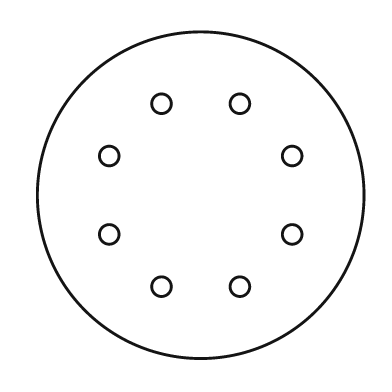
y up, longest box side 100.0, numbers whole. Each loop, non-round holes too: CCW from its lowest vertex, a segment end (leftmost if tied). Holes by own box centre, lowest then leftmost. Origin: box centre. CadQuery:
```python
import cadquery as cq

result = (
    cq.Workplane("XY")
    .moveTo(0.0, 0.0)
    .circle(50.0)
    .moveTo(-12.0, -28.0)
    .circle(3.0)
    .moveTo(12.0, -28.0)
    .circle(3.0)
    .moveTo(-28.0, -12.0)
    .circle(3.0)
    .moveTo(28.0, -12.0)
    .circle(3.0)
    .moveTo(-28.0, 12.0)
    .circle(3.0)
    .moveTo(28.0, 12.0)
    .circle(3.0)
    .moveTo(-12.0, 28.0)
    .circle(3.0)
    .moveTo(12.0, 28.0)
    .circle(3.0)
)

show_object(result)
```